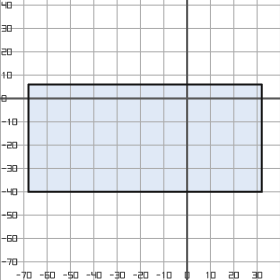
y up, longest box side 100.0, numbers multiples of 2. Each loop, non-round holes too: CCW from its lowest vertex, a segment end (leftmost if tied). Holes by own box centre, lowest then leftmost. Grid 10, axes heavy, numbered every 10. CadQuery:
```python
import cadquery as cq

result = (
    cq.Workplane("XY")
    .moveTo(-68.0, -40.0)
    .lineTo(32.0, -40.0)
    .lineTo(32.0, 6.0)
    .lineTo(-68.0, 6.0)
    .close()
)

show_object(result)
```